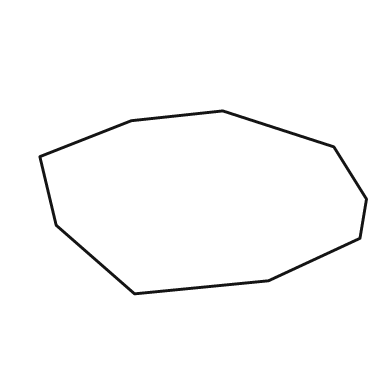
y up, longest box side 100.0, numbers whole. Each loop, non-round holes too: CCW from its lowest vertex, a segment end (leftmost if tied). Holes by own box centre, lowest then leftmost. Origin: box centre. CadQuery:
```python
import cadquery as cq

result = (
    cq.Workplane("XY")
    .moveTo(-21.0, -28.0)
    .lineTo(20.0, -24.0)
    .lineTo(48.0, -11.0)
    .lineTo(50.0, 1.0)
    .lineTo(40.0, 17.0)
    .lineTo(6.0, 28.0)
    .lineTo(-22.0, 25.0)
    .lineTo(-50.0, 14.0)
    .lineTo(-45.0, -7.0)
    .close()
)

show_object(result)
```